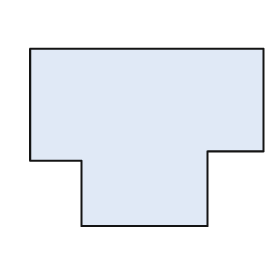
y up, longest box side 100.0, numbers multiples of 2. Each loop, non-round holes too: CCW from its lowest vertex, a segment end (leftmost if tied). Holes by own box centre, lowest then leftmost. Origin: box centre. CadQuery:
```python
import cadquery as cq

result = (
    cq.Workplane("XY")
    .moveTo(-28.0, -38.0)
    .lineTo(26.0, -38.0)
    .lineTo(26.0, -6.0)
    .lineTo(50.0, -6.0)
    .lineTo(50.0, 38.0)
    .lineTo(-50.0, 38.0)
    .lineTo(-50.0, -10.0)
    .lineTo(-28.0, -10.0)
    .close()
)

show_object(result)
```